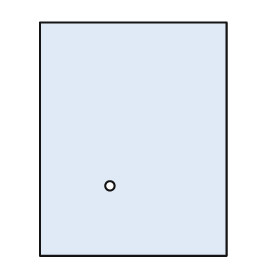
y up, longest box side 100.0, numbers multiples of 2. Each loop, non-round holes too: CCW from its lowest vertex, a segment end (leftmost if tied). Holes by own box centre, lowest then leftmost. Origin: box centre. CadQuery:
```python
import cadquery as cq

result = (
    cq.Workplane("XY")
    .moveTo(-40.0, -50.0)
    .lineTo(40.0, -50.0)
    .lineTo(40.0, 50.0)
    .lineTo(-40.0, 50.0)
    .close()
    .moveTo(-10.0, -20.0)
    .circle(2.0)
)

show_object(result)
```